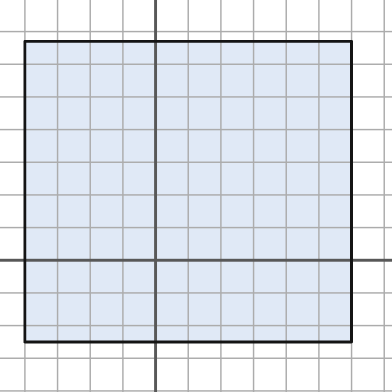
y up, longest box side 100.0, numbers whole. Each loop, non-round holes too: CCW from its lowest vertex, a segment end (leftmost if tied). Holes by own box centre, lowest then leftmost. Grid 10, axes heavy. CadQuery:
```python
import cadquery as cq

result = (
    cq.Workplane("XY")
    .moveTo(-40.0, -25.0)
    .lineTo(60.0, -25.0)
    .lineTo(60.0, 67.0)
    .lineTo(-40.0, 67.0)
    .close()
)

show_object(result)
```